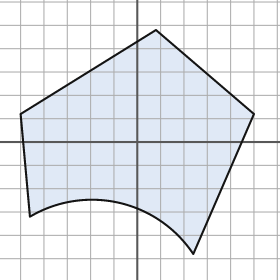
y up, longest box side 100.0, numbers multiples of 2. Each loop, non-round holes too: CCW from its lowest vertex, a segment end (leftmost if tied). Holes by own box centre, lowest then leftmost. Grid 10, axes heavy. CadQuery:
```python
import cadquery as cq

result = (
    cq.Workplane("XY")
    .moveTo(24.0, -48.0)
    .lineTo(50.0, 12.0)
    .lineTo(8.0, 48.0)
    .lineTo(-50.0, 12.0)
    .lineTo(-46.0, -32.0)
    .threePointArc((-8.0, -26.0), (24.0, -48.0))
    .close()
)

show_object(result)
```